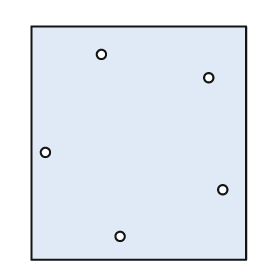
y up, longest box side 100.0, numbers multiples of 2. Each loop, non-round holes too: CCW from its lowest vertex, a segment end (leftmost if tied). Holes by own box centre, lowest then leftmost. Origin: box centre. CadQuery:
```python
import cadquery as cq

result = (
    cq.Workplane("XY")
    .moveTo(-46.0, -50.0)
    .lineTo(46.0, -50.0)
    .lineTo(46.0, 50.0)
    .lineTo(-46.0, 50.0)
    .close()
    .moveTo(-8.0, -40.0)
    .circle(2.0)
    .moveTo(36.0, -20.0)
    .circle(2.0)
    .moveTo(-40.0, -4.0)
    .circle(2.0)
    .moveTo(30.0, 28.0)
    .circle(2.0)
    .moveTo(-16.0, 38.0)
    .circle(2.0)
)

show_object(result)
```